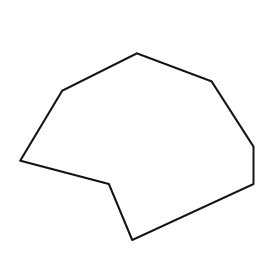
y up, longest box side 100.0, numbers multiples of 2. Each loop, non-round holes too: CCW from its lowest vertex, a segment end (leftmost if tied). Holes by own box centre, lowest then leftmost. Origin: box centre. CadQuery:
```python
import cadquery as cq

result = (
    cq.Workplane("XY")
    .moveTo(-2.0, -40.0)
    .lineTo(50.0, -16.0)
    .lineTo(50.0, 0.0)
    .lineTo(32.0, 28.0)
    .lineTo(0.0, 40.0)
    .lineTo(-32.0, 24.0)
    .lineTo(-50.0, -6.0)
    .lineTo(-12.0, -16.0)
    .close()
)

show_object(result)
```